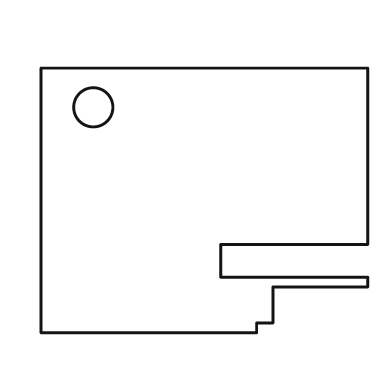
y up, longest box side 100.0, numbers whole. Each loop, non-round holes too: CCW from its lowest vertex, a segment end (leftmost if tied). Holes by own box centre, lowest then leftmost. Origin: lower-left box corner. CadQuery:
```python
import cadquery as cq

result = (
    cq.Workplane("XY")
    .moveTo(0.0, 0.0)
    .lineTo(66.0, 0.0)
    .lineTo(66.0, 3.0)
    .lineTo(71.0, 3.0)
    .lineTo(71.0, 14.0)
    .lineTo(100.0, 14.0)
    .lineTo(100.0, 17.0)
    .lineTo(55.0, 17.0)
    .lineTo(55.0, 27.0)
    .lineTo(100.0, 27.0)
    .lineTo(100.0, 81.0)
    .lineTo(0.0, 81.0)
    .close()
    .moveTo(16.0, 69.0)
    .circle(6.0)
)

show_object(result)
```